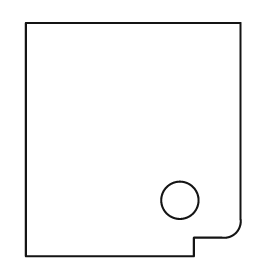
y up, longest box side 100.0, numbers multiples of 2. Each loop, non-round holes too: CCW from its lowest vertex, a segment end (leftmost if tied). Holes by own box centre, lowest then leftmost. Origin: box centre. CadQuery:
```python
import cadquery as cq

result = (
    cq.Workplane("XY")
    .moveTo(-46.0, -50.0)
    .lineTo(26.0, -50.0)
    .lineTo(26.0, -42.0)
    .lineTo(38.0, -42.0)
    .threePointArc((44.0, -40.0), (46.0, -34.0))
    .lineTo(46.0, 50.0)
    .lineTo(-46.0, 50.0)
    .close()
    .moveTo(20.0, -26.0)
    .circle(8.0)
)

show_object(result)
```